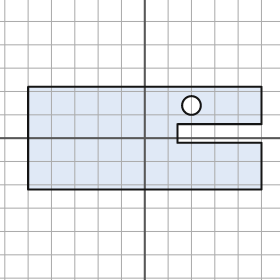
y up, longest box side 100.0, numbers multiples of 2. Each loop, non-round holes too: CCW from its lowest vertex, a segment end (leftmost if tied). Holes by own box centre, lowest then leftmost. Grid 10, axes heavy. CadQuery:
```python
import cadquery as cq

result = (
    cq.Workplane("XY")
    .moveTo(-50.0, -22.0)
    .lineTo(50.0, -22.0)
    .lineTo(50.0, -2.0)
    .lineTo(14.0, -2.0)
    .lineTo(14.0, 6.0)
    .lineTo(50.0, 6.0)
    .lineTo(50.0, 22.0)
    .lineTo(-50.0, 22.0)
    .close()
    .moveTo(20.0, 14.0)
    .circle(4.0)
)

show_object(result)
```